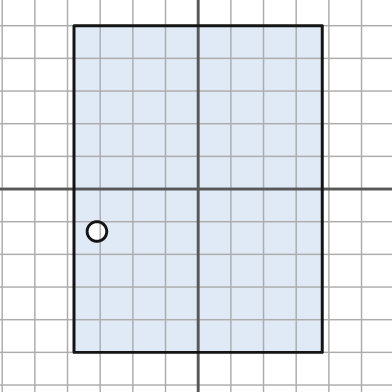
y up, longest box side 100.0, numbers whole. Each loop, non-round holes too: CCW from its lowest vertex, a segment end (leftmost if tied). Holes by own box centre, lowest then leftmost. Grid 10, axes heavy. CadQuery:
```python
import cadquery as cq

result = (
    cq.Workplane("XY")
    .moveTo(-38.0, -50.0)
    .lineTo(38.0, -50.0)
    .lineTo(38.0, 50.0)
    .lineTo(-38.0, 50.0)
    .close()
    .moveTo(-31.0, -13.0)
    .circle(3.0)
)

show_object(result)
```